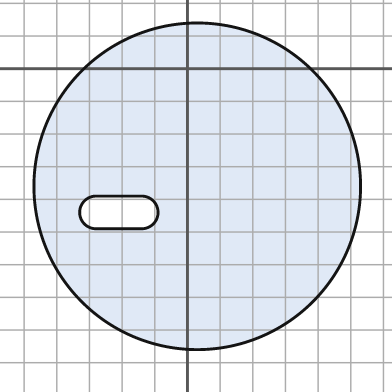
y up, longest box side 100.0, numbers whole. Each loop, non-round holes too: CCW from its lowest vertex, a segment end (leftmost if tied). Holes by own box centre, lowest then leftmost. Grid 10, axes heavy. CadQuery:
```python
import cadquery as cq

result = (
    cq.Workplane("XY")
    .moveTo(3.0, -36.0)
    .circle(50.0)
    .moveTo(-28.0, -49.0)
    .lineTo(-14.0, -49.0)
    .threePointArc((-9.0, -44.0), (-14.0, -39.0))
    .lineTo(-28.0, -39.0)
    .threePointArc((-33.0, -44.0), (-28.0, -49.0))
    .close()
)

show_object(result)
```